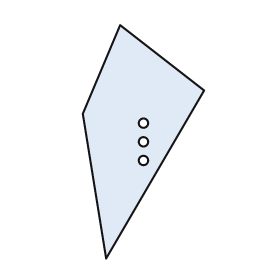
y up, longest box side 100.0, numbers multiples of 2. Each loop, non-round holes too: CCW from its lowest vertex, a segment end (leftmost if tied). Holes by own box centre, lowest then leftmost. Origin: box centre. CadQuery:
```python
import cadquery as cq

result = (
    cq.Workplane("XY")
    .moveTo(-16.0, -50.0)
    .lineTo(26.0, 22.0)
    .lineTo(-10.0, 50.0)
    .lineTo(-26.0, 12.0)
    .close()
    .moveTo(0.0, -8.0)
    .circle(2.0)
    .moveTo(0.0, 0.0)
    .circle(2.0)
    .moveTo(0.0, 8.0)
    .circle(2.0)
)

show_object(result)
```